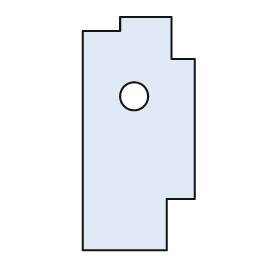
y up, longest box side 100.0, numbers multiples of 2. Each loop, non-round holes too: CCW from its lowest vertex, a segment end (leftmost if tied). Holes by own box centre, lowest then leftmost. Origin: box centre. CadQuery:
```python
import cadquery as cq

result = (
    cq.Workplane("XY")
    .moveTo(-24.0, -50.0)
    .lineTo(12.0, -50.0)
    .lineTo(12.0, -28.0)
    .lineTo(24.0, -28.0)
    .lineTo(24.0, 32.0)
    .lineTo(14.0, 32.0)
    .lineTo(14.0, 50.0)
    .lineTo(-8.0, 50.0)
    .lineTo(-8.0, 44.0)
    .lineTo(-24.0, 44.0)
    .close()
    .moveTo(-2.0, 16.0)
    .circle(6.0)
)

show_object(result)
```